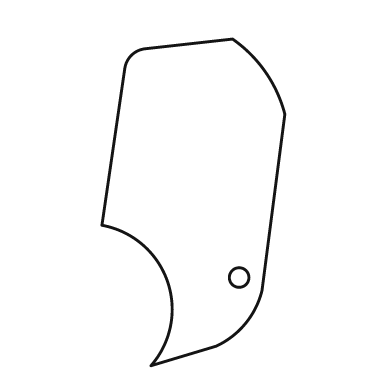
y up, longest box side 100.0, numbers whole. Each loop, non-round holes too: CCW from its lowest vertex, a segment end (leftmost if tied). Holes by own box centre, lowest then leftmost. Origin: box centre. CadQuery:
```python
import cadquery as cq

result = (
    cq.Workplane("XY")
    .moveTo(-13.0, -50.0)
    .lineTo(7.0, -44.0)
    .threePointArc((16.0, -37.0), (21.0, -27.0))
    .lineTo(28.0, 27.0)
    .threePointArc((22.0, 40.0), (12.0, 50.0))
    .lineTo(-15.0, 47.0)
    .threePointArc((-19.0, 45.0), (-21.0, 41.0))
    .lineTo(-28.0, -7.0)
    .threePointArc((-8.0, -24.0), (-13.0, -50.0))
    .close()
    .moveTo(14.0, -23.0)
    .circle(3.0)
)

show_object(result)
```